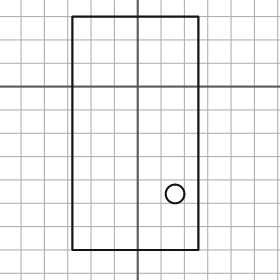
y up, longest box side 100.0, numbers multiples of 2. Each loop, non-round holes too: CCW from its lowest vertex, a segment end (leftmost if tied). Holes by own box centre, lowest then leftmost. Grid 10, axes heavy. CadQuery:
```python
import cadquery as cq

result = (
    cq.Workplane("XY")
    .moveTo(-28.0, -70.0)
    .lineTo(26.0, -70.0)
    .lineTo(26.0, 30.0)
    .lineTo(-28.0, 30.0)
    .close()
    .moveTo(16.0, -46.0)
    .circle(4.0)
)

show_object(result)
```